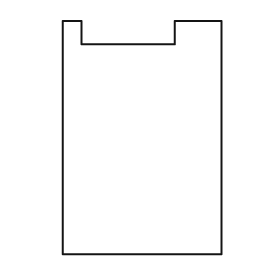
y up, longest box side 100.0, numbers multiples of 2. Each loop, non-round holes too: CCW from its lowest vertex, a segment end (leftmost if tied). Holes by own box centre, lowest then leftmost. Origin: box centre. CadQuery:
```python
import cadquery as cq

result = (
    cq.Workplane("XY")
    .moveTo(-34.0, -50.0)
    .lineTo(34.0, -50.0)
    .lineTo(34.0, 50.0)
    .lineTo(14.0, 50.0)
    .lineTo(14.0, 40.0)
    .lineTo(-26.0, 40.0)
    .lineTo(-26.0, 50.0)
    .lineTo(-34.0, 50.0)
    .close()
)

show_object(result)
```